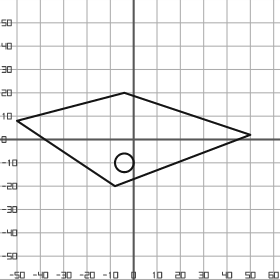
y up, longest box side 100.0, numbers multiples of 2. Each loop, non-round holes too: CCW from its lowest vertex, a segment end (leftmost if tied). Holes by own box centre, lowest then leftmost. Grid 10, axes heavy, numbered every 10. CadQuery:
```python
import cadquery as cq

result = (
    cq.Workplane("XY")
    .moveTo(-8.0, -20.0)
    .lineTo(50.0, 2.0)
    .lineTo(-4.0, 20.0)
    .lineTo(-50.0, 8.0)
    .close()
    .moveTo(-4.0, -10.0)
    .circle(4.0)
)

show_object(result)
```